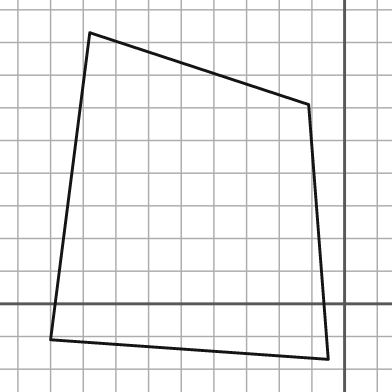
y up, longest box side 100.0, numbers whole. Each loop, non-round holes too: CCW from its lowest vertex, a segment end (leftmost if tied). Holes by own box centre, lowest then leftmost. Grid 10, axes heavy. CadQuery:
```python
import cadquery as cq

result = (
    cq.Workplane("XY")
    .moveTo(-5.0, -17.0)
    .lineTo(-11.0, 61.0)
    .lineTo(-78.0, 83.0)
    .lineTo(-90.0, -11.0)
    .close()
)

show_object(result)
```